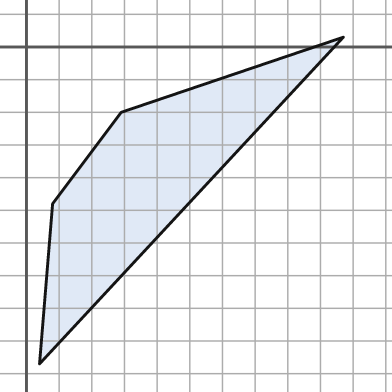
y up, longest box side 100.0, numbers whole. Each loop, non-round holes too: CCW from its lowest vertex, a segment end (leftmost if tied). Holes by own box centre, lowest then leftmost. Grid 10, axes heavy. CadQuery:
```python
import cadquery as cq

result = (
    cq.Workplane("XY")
    .moveTo(4.0, -97.0)
    .lineTo(97.0, 3.0)
    .lineTo(29.0, -20.0)
    .lineTo(8.0, -48.0)
    .close()
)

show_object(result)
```